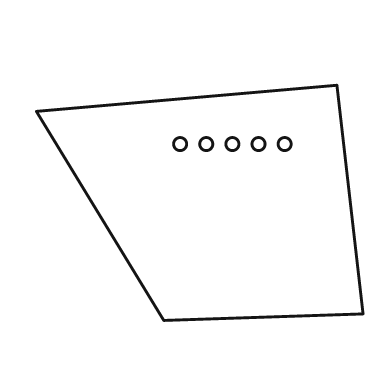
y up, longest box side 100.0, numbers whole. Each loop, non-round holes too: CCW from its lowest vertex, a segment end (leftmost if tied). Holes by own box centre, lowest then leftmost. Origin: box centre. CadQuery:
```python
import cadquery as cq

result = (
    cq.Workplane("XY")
    .moveTo(-11.0, -36.0)
    .lineTo(50.0, -34.0)
    .lineTo(42.0, 36.0)
    .lineTo(-50.0, 28.0)
    .close()
    .moveTo(-6.0, 18.0)
    .circle(2.0)
    .moveTo(2.0, 18.0)
    .circle(2.0)
    .moveTo(10.0, 18.0)
    .circle(2.0)
    .moveTo(18.0, 18.0)
    .circle(2.0)
    .moveTo(26.0, 18.0)
    .circle(2.0)
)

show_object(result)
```